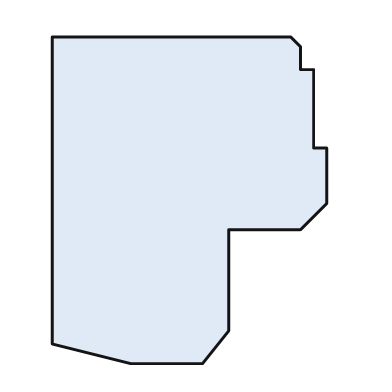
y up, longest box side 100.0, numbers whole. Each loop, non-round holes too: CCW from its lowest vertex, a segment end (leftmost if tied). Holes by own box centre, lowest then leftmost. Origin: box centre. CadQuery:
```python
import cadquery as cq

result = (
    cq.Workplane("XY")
    .moveTo(-18.0, -50.0)
    .lineTo(4.0, -50.0)
    .lineTo(12.0, -40.0)
    .lineTo(12.0, -9.0)
    .lineTo(34.0, -9.0)
    .lineTo(42.0, -1.0)
    .lineTo(42.0, 16.0)
    .lineTo(38.0, 16.0)
    .lineTo(38.0, 40.0)
    .lineTo(34.0, 40.0)
    .lineTo(34.0, 47.0)
    .lineTo(31.0, 50.0)
    .lineTo(-42.0, 50.0)
    .lineTo(-42.0, -44.0)
    .close()
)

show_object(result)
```